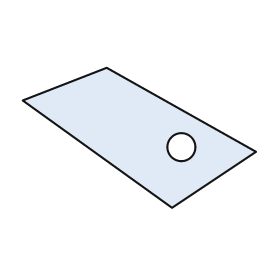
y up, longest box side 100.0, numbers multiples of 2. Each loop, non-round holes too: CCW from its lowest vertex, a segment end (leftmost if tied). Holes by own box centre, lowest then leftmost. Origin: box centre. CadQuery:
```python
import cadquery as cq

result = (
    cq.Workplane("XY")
    .moveTo(14.0, -30.0)
    .lineTo(50.0, -6.0)
    .lineTo(-14.0, 30.0)
    .lineTo(-50.0, 16.0)
    .close()
    .moveTo(18.0, -4.0)
    .circle(6.0)
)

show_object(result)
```